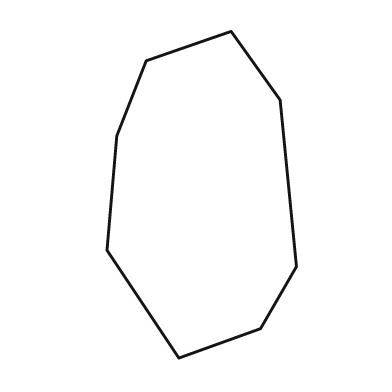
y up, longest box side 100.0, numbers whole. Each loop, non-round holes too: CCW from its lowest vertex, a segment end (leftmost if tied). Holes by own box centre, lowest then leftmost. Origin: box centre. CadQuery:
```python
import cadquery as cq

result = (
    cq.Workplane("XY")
    .moveTo(-7.0, -50.0)
    .lineTo(18.0, -41.0)
    .lineTo(29.0, -22.0)
    .lineTo(24.0, 29.0)
    .lineTo(9.0, 50.0)
    .lineTo(-17.0, 41.0)
    .lineTo(-26.0, 18.0)
    .lineTo(-29.0, -17.0)
    .close()
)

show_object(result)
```